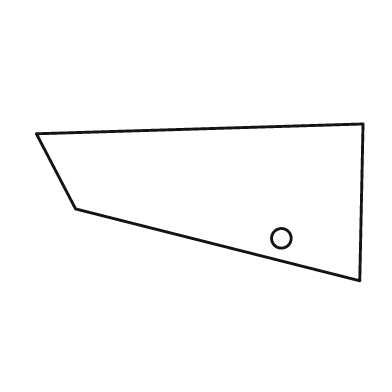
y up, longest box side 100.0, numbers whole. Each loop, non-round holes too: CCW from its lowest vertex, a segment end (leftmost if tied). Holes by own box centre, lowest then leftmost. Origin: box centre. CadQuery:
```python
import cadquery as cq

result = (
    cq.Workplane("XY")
    .moveTo(49.0, -24.0)
    .lineTo(50.0, 24.0)
    .lineTo(-50.0, 21.0)
    .lineTo(-38.0, -2.0)
    .close()
    .moveTo(25.0, -11.0)
    .circle(3.0)
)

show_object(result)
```